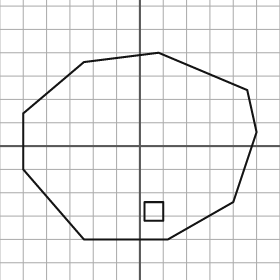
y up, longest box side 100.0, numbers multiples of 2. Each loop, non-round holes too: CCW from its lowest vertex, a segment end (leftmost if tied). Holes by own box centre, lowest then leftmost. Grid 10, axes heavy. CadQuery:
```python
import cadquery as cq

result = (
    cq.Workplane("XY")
    .moveTo(-24.0, -40.0)
    .lineTo(12.0, -40.0)
    .lineTo(40.0, -24.0)
    .lineTo(50.0, 6.0)
    .lineTo(46.0, 24.0)
    .lineTo(8.0, 40.0)
    .lineTo(-24.0, 36.0)
    .lineTo(-50.0, 14.0)
    .lineTo(-50.0, -10.0)
    .close()
    .moveTo(2.0, -32.0)
    .lineTo(10.0, -32.0)
    .lineTo(10.0, -24.0)
    .lineTo(2.0, -24.0)
    .close()
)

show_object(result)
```